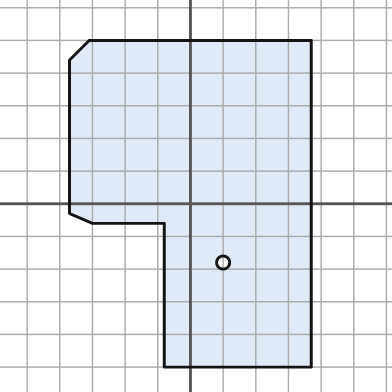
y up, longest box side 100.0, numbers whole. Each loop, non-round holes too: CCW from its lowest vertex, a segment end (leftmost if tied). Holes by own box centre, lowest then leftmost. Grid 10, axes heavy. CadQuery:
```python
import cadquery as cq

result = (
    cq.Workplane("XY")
    .moveTo(-8.0, -50.0)
    .lineTo(37.0, -50.0)
    .lineTo(37.0, 50.0)
    .lineTo(-31.0, 50.0)
    .lineTo(-37.0, 44.0)
    .lineTo(-37.0, -3.0)
    .lineTo(-30.0, -6.0)
    .lineTo(-8.0, -6.0)
    .close()
    .moveTo(10.0, -18.0)
    .circle(2.0)
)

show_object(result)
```